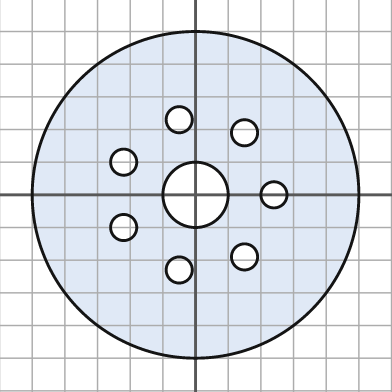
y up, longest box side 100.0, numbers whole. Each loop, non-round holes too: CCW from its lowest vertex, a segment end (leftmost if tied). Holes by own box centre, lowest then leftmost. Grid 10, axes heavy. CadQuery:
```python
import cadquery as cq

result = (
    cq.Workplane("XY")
    .moveTo(0.0, 0.0)
    .circle(50.0)
    .moveTo(-5.0, -23.0)
    .circle(4.0)
    .moveTo(15.0, -19.0)
    .circle(4.0)
    .moveTo(-22.0, -10.0)
    .circle(4.0)
    .moveTo(0.0, 0.0)
    .circle(10.0)
    .moveTo(24.0, 0.0)
    .circle(4.0)
    .moveTo(-22.0, 10.0)
    .circle(4.0)
    .moveTo(15.0, 19.0)
    .circle(4.0)
    .moveTo(-5.0, 23.0)
    .circle(4.0)
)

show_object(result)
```